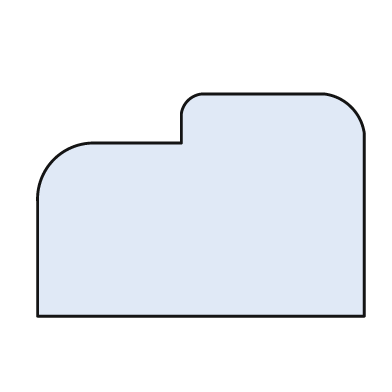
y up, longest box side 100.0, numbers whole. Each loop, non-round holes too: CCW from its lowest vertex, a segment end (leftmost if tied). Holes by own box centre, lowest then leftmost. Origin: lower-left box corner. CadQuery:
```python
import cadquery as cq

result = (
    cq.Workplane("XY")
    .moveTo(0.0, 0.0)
    .lineTo(100.0, 0.0)
    .lineTo(100.0, 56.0)
    .threePointArc((96.0, 64.0), (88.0, 68.0))
    .lineTo(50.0, 68.0)
    .threePointArc((46.0, 66.0), (44.0, 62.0))
    .lineTo(44.0, 53.0)
    .lineTo(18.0, 53.0)
    .threePointArc((5.0, 48.0), (0.0, 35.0))
    .close()
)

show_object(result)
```